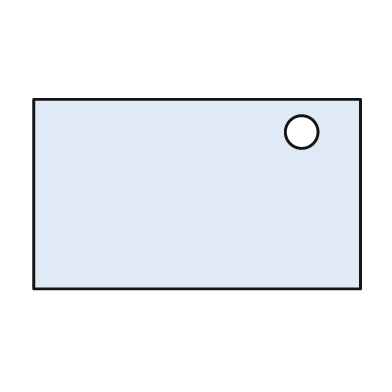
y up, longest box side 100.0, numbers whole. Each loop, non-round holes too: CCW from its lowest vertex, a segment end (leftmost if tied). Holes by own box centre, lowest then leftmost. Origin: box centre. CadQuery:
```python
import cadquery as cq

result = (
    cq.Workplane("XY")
    .moveTo(-50.0, -29.0)
    .lineTo(50.0, -29.0)
    .lineTo(50.0, 29.0)
    .lineTo(-50.0, 29.0)
    .close()
    .moveTo(32.0, 19.0)
    .circle(5.0)
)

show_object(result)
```